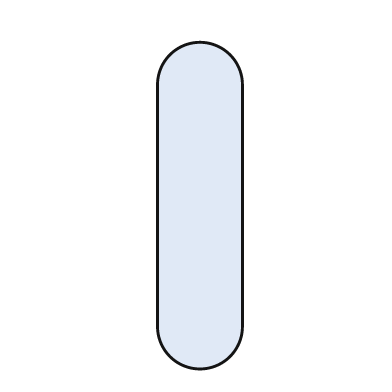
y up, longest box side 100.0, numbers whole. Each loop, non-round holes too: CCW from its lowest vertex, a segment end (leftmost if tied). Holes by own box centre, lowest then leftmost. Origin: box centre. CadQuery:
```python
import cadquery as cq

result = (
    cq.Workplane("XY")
    .moveTo(-13.0, -37.0)
    .threePointArc((0.0, -50.0), (13.0, -37.0))
    .lineTo(13.0, 37.0)
    .threePointArc((0.0, 50.0), (-13.0, 37.0))
    .close()
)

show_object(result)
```